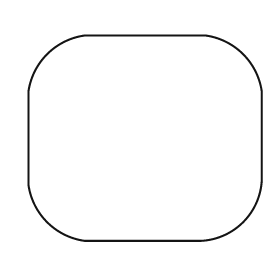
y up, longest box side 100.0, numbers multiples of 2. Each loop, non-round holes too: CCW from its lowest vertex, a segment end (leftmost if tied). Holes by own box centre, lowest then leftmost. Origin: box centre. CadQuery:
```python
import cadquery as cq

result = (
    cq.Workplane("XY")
    .moveTo(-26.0, -44.0)
    .lineTo(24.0, -44.0)
    .threePointArc((42.0, -36.0), (50.0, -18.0))
    .lineTo(50.0, 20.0)
    .threePointArc((42.0, 36.0), (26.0, 44.0))
    .lineTo(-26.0, 44.0)
    .threePointArc((-42.0, 36.0), (-50.0, 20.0))
    .lineTo(-50.0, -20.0)
    .threePointArc((-42.0, -36.0), (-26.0, -44.0))
    .close()
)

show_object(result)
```